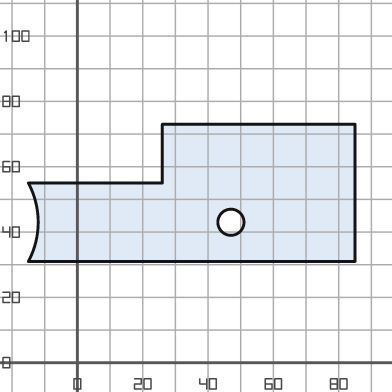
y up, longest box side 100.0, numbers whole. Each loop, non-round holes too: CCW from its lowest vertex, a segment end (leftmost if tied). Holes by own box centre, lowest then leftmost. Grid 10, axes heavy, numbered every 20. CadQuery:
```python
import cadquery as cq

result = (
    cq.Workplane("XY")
    .moveTo(-15.0, 31.0)
    .lineTo(85.0, 31.0)
    .lineTo(85.0, 73.0)
    .lineTo(26.0, 73.0)
    .lineTo(26.0, 55.0)
    .lineTo(-15.0, 55.0)
    .threePointArc((-12.0, 43.0), (-15.0, 31.0))
    .close()
    .moveTo(47.0, 43.0)
    .circle(4.0)
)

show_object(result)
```